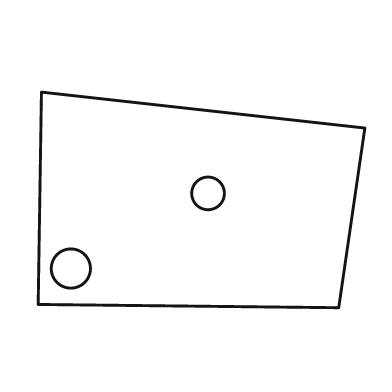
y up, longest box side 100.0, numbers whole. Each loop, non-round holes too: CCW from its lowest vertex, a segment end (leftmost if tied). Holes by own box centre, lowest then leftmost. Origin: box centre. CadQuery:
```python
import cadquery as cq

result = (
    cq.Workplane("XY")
    .moveTo(42.0, -33.0)
    .lineTo(50.0, 22.0)
    .lineTo(-49.0, 33.0)
    .lineTo(-50.0, -32.0)
    .close()
    .moveTo(-40.0, -21.0)
    .circle(6.0)
    .moveTo(2.0, 2.0)
    .circle(5.0)
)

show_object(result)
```